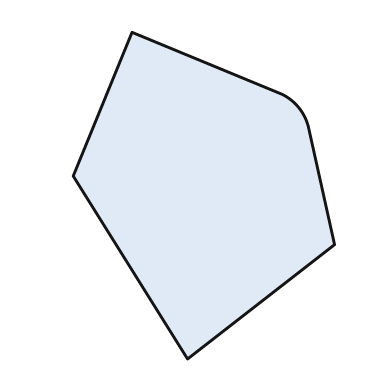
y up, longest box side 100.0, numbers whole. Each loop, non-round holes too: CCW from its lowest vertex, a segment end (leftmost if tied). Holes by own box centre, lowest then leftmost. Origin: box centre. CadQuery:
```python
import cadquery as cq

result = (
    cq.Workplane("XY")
    .moveTo(-5.0, -50.0)
    .lineTo(40.0, -15.0)
    .lineTo(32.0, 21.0)
    .threePointArc((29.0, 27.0), (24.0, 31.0))
    .lineTo(-22.0, 50.0)
    .lineTo(-40.0, 6.0)
    .close()
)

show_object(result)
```